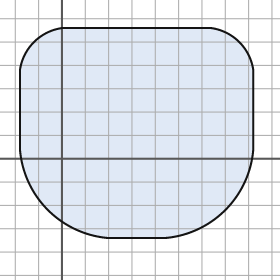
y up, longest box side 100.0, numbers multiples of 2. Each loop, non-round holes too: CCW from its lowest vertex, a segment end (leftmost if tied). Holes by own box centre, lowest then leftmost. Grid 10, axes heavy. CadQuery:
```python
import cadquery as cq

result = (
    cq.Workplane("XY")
    .moveTo(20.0, -34.0)
    .lineTo(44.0, -34.0)
    .threePointArc((70.0, -22.0), (82.0, 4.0))
    .lineTo(82.0, 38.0)
    .threePointArc((76.0, 50.0), (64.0, 56.0))
    .lineTo(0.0, 56.0)
    .threePointArc((-12.0, 50.0), (-18.0, 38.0))
    .lineTo(-18.0, 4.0)
    .threePointArc((-6.0, -22.0), (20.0, -34.0))
    .close()
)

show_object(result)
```